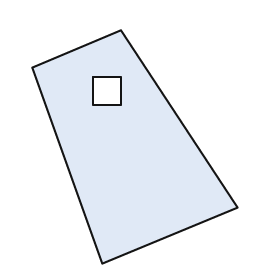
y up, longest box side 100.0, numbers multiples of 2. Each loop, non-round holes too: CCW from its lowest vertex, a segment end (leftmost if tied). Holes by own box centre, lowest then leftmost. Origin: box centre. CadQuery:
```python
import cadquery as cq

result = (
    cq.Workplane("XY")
    .moveTo(-14.0, -50.0)
    .lineTo(44.0, -26.0)
    .lineTo(-6.0, 50.0)
    .lineTo(-44.0, 34.0)
    .close()
    .moveTo(-18.0, 18.0)
    .lineTo(-6.0, 18.0)
    .lineTo(-6.0, 30.0)
    .lineTo(-18.0, 30.0)
    .close()
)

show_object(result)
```